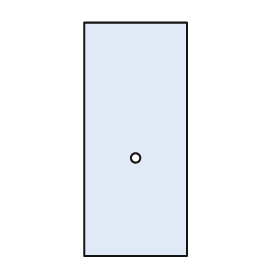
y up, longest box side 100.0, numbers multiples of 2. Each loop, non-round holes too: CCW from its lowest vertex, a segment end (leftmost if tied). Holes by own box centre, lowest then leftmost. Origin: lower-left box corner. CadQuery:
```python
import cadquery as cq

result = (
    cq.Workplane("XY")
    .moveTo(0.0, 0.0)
    .lineTo(44.0, 0.0)
    .lineTo(44.0, 100.0)
    .lineTo(0.0, 100.0)
    .close()
    .moveTo(22.0, 42.0)
    .circle(2.0)
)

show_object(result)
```